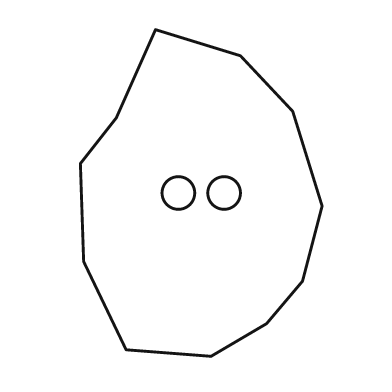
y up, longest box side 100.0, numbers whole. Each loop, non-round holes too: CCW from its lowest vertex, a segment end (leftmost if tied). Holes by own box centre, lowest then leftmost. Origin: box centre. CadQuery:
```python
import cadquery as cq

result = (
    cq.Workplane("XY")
    .moveTo(3.0, -50.0)
    .lineTo(20.0, -40.0)
    .lineTo(31.0, -27.0)
    .lineTo(37.0, -4.0)
    .lineTo(28.0, 25.0)
    .lineTo(12.0, 42.0)
    .lineTo(-14.0, 50.0)
    .lineTo(-26.0, 23.0)
    .lineTo(-37.0, 9.0)
    .lineTo(-36.0, -21.0)
    .lineTo(-23.0, -48.0)
    .close()
    .moveTo(-7.0, 0.0)
    .circle(5.0)
    .moveTo(7.0, 0.0)
    .circle(5.0)
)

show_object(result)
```